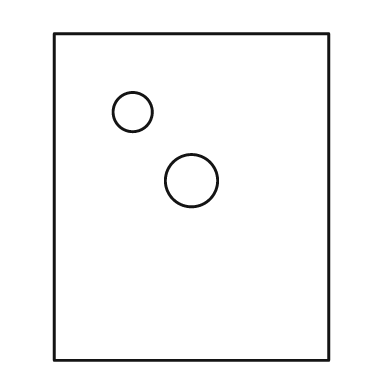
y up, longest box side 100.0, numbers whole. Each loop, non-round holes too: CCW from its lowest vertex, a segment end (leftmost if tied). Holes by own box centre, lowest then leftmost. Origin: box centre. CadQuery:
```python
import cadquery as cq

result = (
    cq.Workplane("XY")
    .moveTo(-42.0, -50.0)
    .lineTo(42.0, -50.0)
    .lineTo(42.0, 50.0)
    .lineTo(-42.0, 50.0)
    .close()
    .moveTo(0.0, 5.0)
    .circle(8.0)
    .moveTo(-18.0, 26.0)
    .circle(6.0)
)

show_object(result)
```